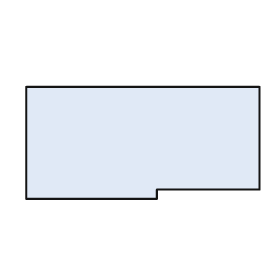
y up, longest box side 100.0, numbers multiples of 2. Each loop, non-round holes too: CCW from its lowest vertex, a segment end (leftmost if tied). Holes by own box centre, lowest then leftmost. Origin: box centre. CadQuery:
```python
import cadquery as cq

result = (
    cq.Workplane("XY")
    .moveTo(-50.0, -24.0)
    .lineTo(6.0, -24.0)
    .lineTo(6.0, -20.0)
    .lineTo(50.0, -20.0)
    .lineTo(50.0, 24.0)
    .lineTo(-50.0, 24.0)
    .close()
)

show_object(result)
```